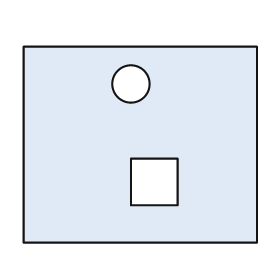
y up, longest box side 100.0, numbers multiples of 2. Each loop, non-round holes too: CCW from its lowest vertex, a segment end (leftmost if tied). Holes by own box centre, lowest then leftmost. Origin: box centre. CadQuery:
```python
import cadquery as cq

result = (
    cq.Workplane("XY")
    .moveTo(-50.0, -42.0)
    .lineTo(50.0, -42.0)
    .lineTo(50.0, 42.0)
    .lineTo(-50.0, 42.0)
    .close()
    .moveTo(-4.0, -26.0)
    .lineTo(16.0, -26.0)
    .lineTo(16.0, -6.0)
    .lineTo(-4.0, -6.0)
    .close()
    .moveTo(-4.0, 26.0)
    .circle(8.0)
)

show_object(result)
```